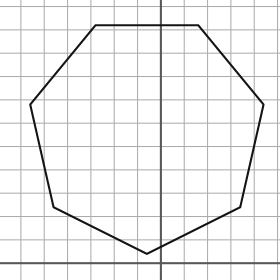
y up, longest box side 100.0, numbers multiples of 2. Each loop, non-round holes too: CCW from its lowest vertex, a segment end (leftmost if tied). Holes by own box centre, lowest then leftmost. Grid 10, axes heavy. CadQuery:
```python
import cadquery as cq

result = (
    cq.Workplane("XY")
    .moveTo(-6.0, 4.0)
    .lineTo(34.0, 24.0)
    .lineTo(44.0, 68.0)
    .lineTo(16.0, 102.0)
    .lineTo(-28.0, 102.0)
    .lineTo(-56.0, 68.0)
    .lineTo(-46.0, 24.0)
    .close()
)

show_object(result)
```